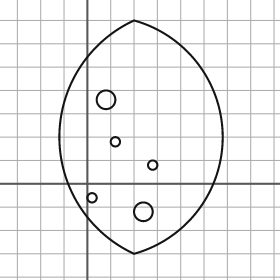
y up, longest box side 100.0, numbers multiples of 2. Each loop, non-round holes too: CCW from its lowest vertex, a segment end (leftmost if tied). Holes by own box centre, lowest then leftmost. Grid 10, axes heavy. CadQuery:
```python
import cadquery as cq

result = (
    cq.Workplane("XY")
    .moveTo(20.0, -30.0)
    .threePointArc((58.0, 20.0), (20.0, 70.0))
    .threePointArc((-12.0, 20.0), (20.0, -30.0))
    .close()
    .moveTo(24.0, -12.0)
    .circle(4.0)
    .moveTo(2.0, -6.0)
    .circle(2.0)
    .moveTo(28.0, 8.0)
    .circle(2.0)
    .moveTo(12.0, 18.0)
    .circle(2.0)
    .moveTo(8.0, 36.0)
    .circle(4.0)
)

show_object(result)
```